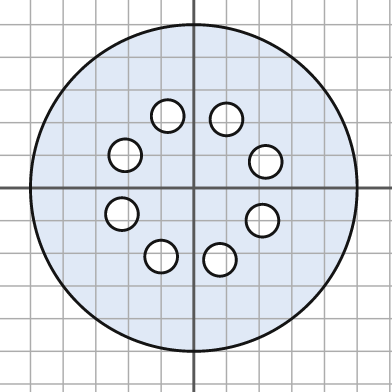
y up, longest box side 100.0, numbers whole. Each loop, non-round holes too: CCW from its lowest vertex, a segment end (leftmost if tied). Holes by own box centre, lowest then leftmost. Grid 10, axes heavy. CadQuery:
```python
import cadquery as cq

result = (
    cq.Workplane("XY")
    .moveTo(0.0, 0.0)
    .circle(50.0)
    .moveTo(8.0, -22.0)
    .circle(5.0)
    .moveTo(-10.0, -21.0)
    .circle(5.0)
    .moveTo(21.0, -10.0)
    .circle(5.0)
    .moveTo(-22.0, -8.0)
    .circle(5.0)
    .moveTo(22.0, 8.0)
    .circle(5.0)
    .moveTo(-21.0, 10.0)
    .circle(5.0)
    .moveTo(10.0, 21.0)
    .circle(5.0)
    .moveTo(-8.0, 22.0)
    .circle(5.0)
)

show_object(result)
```